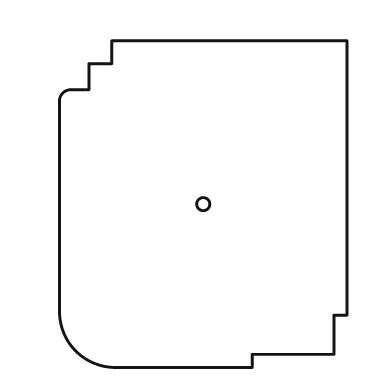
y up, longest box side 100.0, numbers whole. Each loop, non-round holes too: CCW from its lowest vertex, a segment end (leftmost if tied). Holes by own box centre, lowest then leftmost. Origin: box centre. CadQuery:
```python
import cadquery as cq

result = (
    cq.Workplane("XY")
    .moveTo(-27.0, -50.0)
    .lineTo(15.0, -50.0)
    .lineTo(15.0, -46.0)
    .lineTo(40.0, -46.0)
    .lineTo(40.0, -34.0)
    .lineTo(44.0, -34.0)
    .lineTo(44.0, 50.0)
    .lineTo(-28.0, 50.0)
    .lineTo(-28.0, 43.0)
    .lineTo(-35.0, 43.0)
    .lineTo(-35.0, 35.0)
    .lineTo(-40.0, 35.0)
    .threePointArc((-43.0, 34.0), (-44.0, 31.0))
    .lineTo(-44.0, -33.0)
    .threePointArc((-39.0, -45.0), (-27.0, -50.0))
    .close()
    .moveTo(0.0, 0.0)
    .circle(2.0)
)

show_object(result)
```